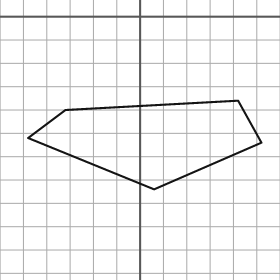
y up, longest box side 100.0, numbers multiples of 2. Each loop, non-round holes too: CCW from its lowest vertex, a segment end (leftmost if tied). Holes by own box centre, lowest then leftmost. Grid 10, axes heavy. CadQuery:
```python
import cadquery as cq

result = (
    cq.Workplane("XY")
    .moveTo(6.0, -74.0)
    .lineTo(52.0, -54.0)
    .lineTo(42.0, -36.0)
    .lineTo(-32.0, -40.0)
    .lineTo(-48.0, -52.0)
    .close()
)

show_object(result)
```